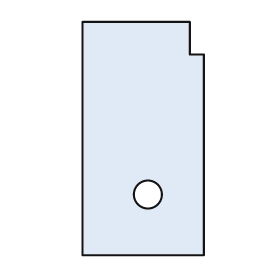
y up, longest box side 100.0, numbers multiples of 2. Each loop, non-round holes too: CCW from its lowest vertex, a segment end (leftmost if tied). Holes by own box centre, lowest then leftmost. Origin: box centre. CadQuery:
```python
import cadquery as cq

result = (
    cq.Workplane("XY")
    .moveTo(-26.0, -50.0)
    .lineTo(26.0, -50.0)
    .lineTo(26.0, 36.0)
    .lineTo(20.0, 36.0)
    .lineTo(20.0, 50.0)
    .lineTo(-26.0, 50.0)
    .close()
    .moveTo(2.0, -24.0)
    .circle(6.0)
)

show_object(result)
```